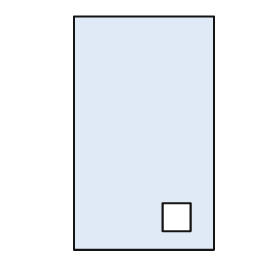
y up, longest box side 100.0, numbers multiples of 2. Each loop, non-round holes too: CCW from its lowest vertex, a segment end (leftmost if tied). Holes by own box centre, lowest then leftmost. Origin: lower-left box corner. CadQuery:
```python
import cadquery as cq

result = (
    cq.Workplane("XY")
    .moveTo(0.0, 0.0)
    .lineTo(60.0, 0.0)
    .lineTo(60.0, 100.0)
    .lineTo(0.0, 100.0)
    .close()
    .moveTo(38.0, 8.0)
    .lineTo(50.0, 8.0)
    .lineTo(50.0, 20.0)
    .lineTo(38.0, 20.0)
    .close()
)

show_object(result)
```